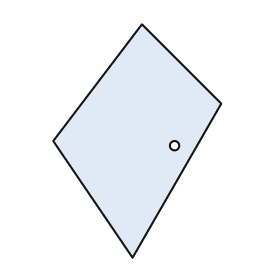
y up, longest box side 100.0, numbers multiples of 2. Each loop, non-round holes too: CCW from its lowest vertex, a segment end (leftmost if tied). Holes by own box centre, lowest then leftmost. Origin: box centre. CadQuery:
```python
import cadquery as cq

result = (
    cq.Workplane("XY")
    .moveTo(-2.0, -50.0)
    .lineTo(36.0, 16.0)
    .lineTo(2.0, 50.0)
    .lineTo(-36.0, 0.0)
    .close()
    .moveTo(16.0, -2.0)
    .circle(2.0)
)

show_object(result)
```